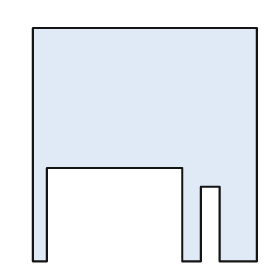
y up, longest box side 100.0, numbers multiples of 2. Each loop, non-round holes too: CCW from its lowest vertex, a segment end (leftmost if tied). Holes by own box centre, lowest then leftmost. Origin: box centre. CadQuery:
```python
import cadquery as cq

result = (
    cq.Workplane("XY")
    .moveTo(-48.0, -50.0)
    .lineTo(-42.0, -50.0)
    .lineTo(-42.0, -10.0)
    .lineTo(16.0, -10.0)
    .lineTo(16.0, -50.0)
    .lineTo(24.0, -50.0)
    .lineTo(24.0, -18.0)
    .lineTo(32.0, -18.0)
    .lineTo(32.0, -50.0)
    .lineTo(48.0, -50.0)
    .lineTo(48.0, 50.0)
    .lineTo(-48.0, 50.0)
    .close()
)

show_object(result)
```